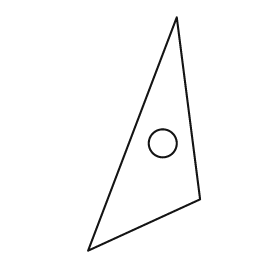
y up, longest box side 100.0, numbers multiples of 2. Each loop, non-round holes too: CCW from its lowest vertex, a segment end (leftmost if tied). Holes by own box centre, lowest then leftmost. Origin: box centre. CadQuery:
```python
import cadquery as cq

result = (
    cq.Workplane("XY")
    .moveTo(-24.0, -50.0)
    .lineTo(24.0, -28.0)
    .lineTo(14.0, 50.0)
    .close()
    .moveTo(8.0, -4.0)
    .circle(6.0)
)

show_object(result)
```